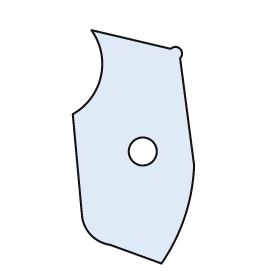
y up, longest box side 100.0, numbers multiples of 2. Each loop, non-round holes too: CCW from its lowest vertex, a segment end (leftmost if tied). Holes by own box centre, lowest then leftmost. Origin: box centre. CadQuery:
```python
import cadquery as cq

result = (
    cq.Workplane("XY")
    .moveTo(12.0, -50.0)
    .threePointArc((22.0, -30.0), (26.0, -8.0))
    .lineTo(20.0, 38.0)
    .threePointArc((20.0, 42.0), (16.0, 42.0))
    .lineTo(-18.0, 50.0)
    .threePointArc((-14.0, 30.0), (-26.0, 14.0))
    .lineTo(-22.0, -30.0)
    .threePointArc((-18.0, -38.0), (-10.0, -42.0))
    .close()
    .moveTo(4.0, -2.0)
    .circle(6.0)
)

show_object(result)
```